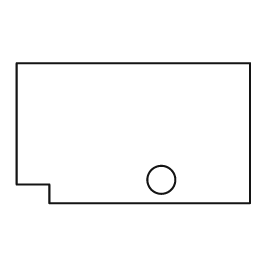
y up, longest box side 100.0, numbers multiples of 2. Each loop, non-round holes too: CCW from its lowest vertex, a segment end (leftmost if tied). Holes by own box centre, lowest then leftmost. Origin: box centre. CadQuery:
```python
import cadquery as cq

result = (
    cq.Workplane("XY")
    .moveTo(-36.0, -30.0)
    .lineTo(50.0, -30.0)
    .lineTo(50.0, 30.0)
    .lineTo(-50.0, 30.0)
    .lineTo(-50.0, -22.0)
    .lineTo(-36.0, -22.0)
    .close()
    .moveTo(12.0, -20.0)
    .circle(6.0)
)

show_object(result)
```